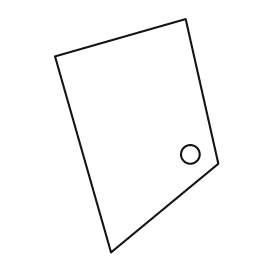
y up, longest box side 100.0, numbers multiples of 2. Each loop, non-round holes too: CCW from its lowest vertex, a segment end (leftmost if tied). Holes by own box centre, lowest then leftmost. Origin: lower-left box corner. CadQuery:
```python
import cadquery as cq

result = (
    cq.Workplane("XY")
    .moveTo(24.0, 0.0)
    .lineTo(70.0, 38.0)
    .lineTo(56.0, 100.0)
    .lineTo(0.0, 84.0)
    .close()
    .moveTo(58.0, 42.0)
    .circle(4.0)
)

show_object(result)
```